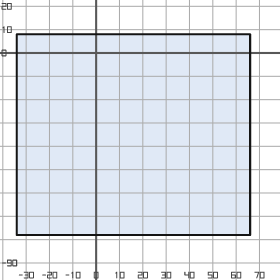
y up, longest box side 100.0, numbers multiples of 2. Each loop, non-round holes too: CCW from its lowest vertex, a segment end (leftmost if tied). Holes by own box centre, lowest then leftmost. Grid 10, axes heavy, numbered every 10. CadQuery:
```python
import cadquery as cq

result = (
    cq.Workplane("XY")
    .moveTo(-34.0, -78.0)
    .lineTo(66.0, -78.0)
    .lineTo(66.0, 8.0)
    .lineTo(-34.0, 8.0)
    .close()
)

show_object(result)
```